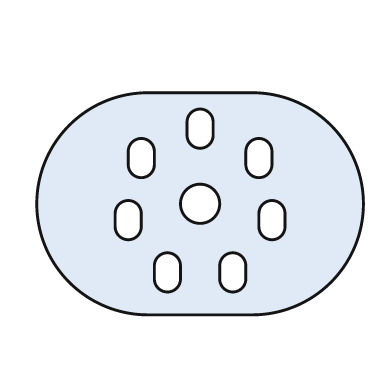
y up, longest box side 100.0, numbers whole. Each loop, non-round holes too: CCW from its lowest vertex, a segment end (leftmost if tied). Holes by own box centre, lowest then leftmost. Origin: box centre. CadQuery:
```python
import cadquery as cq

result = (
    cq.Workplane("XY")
    .moveTo(-16.0, -34.0)
    .lineTo(16.0, -34.0)
    .threePointArc((50.0, 0.0), (16.0, 34.0))
    .lineTo(-16.0, 34.0)
    .threePointArc((-50.0, 0.0), (-16.0, -34.0))
    .close()
    .moveTo(-14.0, -23.0)
    .threePointArc((-10.0, -27.0), (-6.0, -23.0))
    .lineTo(-6.0, -19.0)
    .threePointArc((-10.0, -15.0), (-14.0, -19.0))
    .close()
    .moveTo(6.0, -23.0)
    .threePointArc((10.0, -27.0), (14.0, -23.0))
    .lineTo(14.0, -19.0)
    .threePointArc((10.0, -15.0), (6.0, -19.0))
    .close()
    .moveTo(-26.0, -7.0)
    .threePointArc((-22.0, -11.0), (-18.0, -7.0))
    .lineTo(-18.0, -3.0)
    .threePointArc((-22.0, 1.0), (-26.0, -3.0))
    .close()
    .moveTo(18.0, -7.0)
    .threePointArc((22.0, -11.0), (26.0, -7.0))
    .lineTo(26.0, -3.0)
    .threePointArc((22.0, 1.0), (18.0, -3.0))
    .close()
    .moveTo(0.0, 0.0)
    .circle(6.0)
    .moveTo(-22.0, 12.0)
    .threePointArc((-18.0, 8.0), (-14.0, 12.0))
    .lineTo(-14.0, 16.0)
    .threePointArc((-18.0, 20.0), (-22.0, 16.0))
    .close()
    .moveTo(14.0, 12.0)
    .threePointArc((18.0, 8.0), (22.0, 12.0))
    .lineTo(22.0, 16.0)
    .threePointArc((18.0, 20.0), (14.0, 16.0))
    .close()
    .moveTo(-4.0, 21.0)
    .threePointArc((0.0, 17.0), (4.0, 21.0))
    .lineTo(4.0, 25.0)
    .threePointArc((0.0, 29.0), (-4.0, 25.0))
    .close()
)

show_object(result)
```